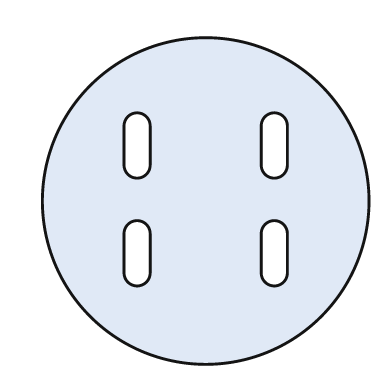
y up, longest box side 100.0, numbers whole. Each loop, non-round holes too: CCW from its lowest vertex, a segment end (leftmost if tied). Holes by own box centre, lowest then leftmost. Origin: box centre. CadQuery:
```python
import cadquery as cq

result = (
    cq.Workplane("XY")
    .moveTo(0.0, 0.0)
    .circle(50.0)
    .moveTo(-25.0, -22.0)
    .threePointArc((-21.0, -26.0), (-17.0, -22.0))
    .lineTo(-17.0, -10.0)
    .threePointArc((-21.0, -6.0), (-25.0, -10.0))
    .close()
    .moveTo(17.0, -22.0)
    .threePointArc((21.0, -26.0), (25.0, -22.0))
    .lineTo(25.0, -10.0)
    .threePointArc((21.0, -6.0), (17.0, -10.0))
    .close()
    .moveTo(-25.0, 11.0)
    .threePointArc((-21.0, 7.0), (-17.0, 11.0))
    .lineTo(-17.0, 23.0)
    .threePointArc((-21.0, 27.0), (-25.0, 23.0))
    .close()
    .moveTo(17.0, 11.0)
    .threePointArc((21.0, 7.0), (25.0, 11.0))
    .lineTo(25.0, 23.0)
    .threePointArc((21.0, 27.0), (17.0, 23.0))
    .close()
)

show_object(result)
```